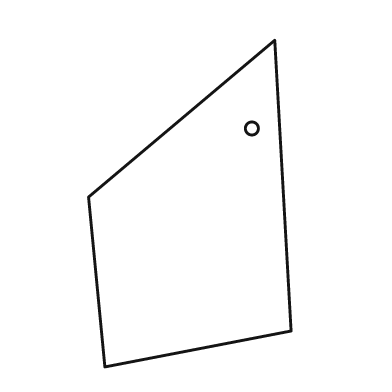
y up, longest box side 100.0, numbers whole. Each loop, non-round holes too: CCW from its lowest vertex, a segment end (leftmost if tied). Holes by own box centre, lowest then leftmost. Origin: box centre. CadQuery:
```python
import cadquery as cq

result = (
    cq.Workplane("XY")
    .moveTo(-26.0, -50.0)
    .lineTo(31.0, -39.0)
    .lineTo(26.0, 50.0)
    .lineTo(-31.0, 2.0)
    .close()
    .moveTo(19.0, 23.0)
    .circle(2.0)
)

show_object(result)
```